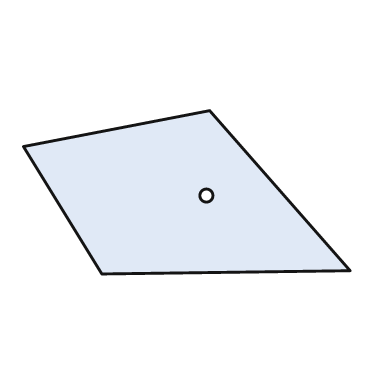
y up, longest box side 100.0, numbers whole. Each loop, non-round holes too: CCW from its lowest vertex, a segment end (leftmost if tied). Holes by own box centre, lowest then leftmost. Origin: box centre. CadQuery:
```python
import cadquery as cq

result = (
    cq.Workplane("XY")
    .moveTo(-26.0, -25.0)
    .lineTo(50.0, -24.0)
    .lineTo(7.0, 25.0)
    .lineTo(-50.0, 14.0)
    .close()
    .moveTo(6.0, -1.0)
    .circle(2.0)
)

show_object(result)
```